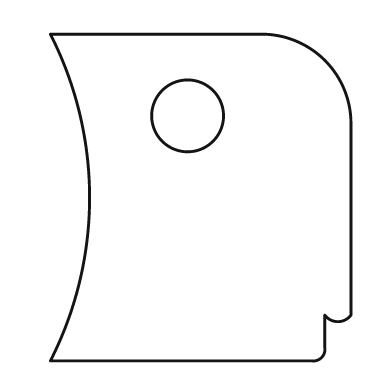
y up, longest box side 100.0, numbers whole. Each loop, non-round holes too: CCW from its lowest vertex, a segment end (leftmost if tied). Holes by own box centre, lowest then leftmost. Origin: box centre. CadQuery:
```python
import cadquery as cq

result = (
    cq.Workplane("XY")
    .moveTo(-46.0, -50.0)
    .lineTo(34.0, -50.0)
    .threePointArc((37.0, -49.0), (38.0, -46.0))
    .lineTo(38.0, -36.0)
    .threePointArc((42.0, -38.0), (46.0, -36.0))
    .lineTo(46.0, 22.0)
    .threePointArc((38.0, 42.0), (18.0, 50.0))
    .lineTo(-46.0, 50.0)
    .threePointArc((-34.0, 0.0), (-46.0, -50.0))
    .close()
    .moveTo(-4.0, 25.0)
    .circle(11.0)
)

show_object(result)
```